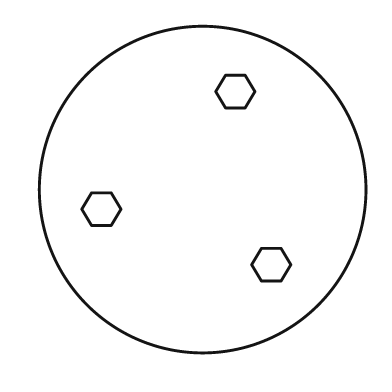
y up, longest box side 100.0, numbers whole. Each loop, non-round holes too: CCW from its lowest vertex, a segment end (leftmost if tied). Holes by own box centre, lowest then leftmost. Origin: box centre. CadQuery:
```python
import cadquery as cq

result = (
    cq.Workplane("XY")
    .moveTo(0.0, 0.0)
    .circle(50.0)
    .moveTo(18.0, -28.0)
    .lineTo(24.0, -28.0)
    .lineTo(27.0, -23.0)
    .lineTo(24.0, -18.0)
    .lineTo(18.0, -18.0)
    .lineTo(15.0, -23.0)
    .close()
    .moveTo(-34.0, -11.0)
    .lineTo(-28.0, -11.0)
    .lineTo(-25.0, -6.0)
    .lineTo(-28.0, -1.0)
    .lineTo(-34.0, -1.0)
    .lineTo(-37.0, -6.0)
    .close()
    .moveTo(7.0, 25.0)
    .lineTo(13.0, 25.0)
    .lineTo(16.0, 30.0)
    .lineTo(13.0, 35.0)
    .lineTo(7.0, 35.0)
    .lineTo(4.0, 30.0)
    .close()
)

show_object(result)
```